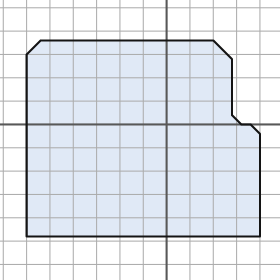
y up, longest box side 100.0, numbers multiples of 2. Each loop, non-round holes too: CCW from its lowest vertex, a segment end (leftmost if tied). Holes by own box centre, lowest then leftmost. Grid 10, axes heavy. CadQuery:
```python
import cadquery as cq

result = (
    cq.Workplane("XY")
    .moveTo(-60.0, -48.0)
    .lineTo(40.0, -48.0)
    .lineTo(40.0, -4.0)
    .lineTo(36.0, 0.0)
    .lineTo(32.0, 0.0)
    .lineTo(28.0, 4.0)
    .lineTo(28.0, 28.0)
    .lineTo(20.0, 36.0)
    .lineTo(-54.0, 36.0)
    .lineTo(-60.0, 30.0)
    .close()
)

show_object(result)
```